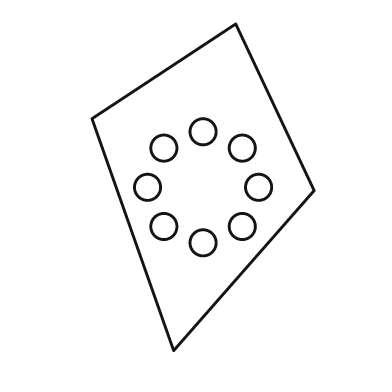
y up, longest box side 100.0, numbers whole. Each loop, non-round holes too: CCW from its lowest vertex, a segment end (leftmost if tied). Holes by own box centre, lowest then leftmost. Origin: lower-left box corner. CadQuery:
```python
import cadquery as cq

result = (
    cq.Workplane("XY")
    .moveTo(25.0, 0.0)
    .lineTo(68.0, 49.0)
    .lineTo(44.0, 100.0)
    .lineTo(0.0, 71.0)
    .close()
    .moveTo(34.0, 33.0)
    .circle(4.0)
    .moveTo(22.0, 38.0)
    .circle(4.0)
    .moveTo(46.0, 38.0)
    .circle(4.0)
    .moveTo(17.0, 50.0)
    .circle(4.0)
    .moveTo(51.0, 50.0)
    .circle(4.0)
    .moveTo(22.0, 62.0)
    .circle(4.0)
    .moveTo(46.0, 62.0)
    .circle(4.0)
    .moveTo(34.0, 67.0)
    .circle(4.0)
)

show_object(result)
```